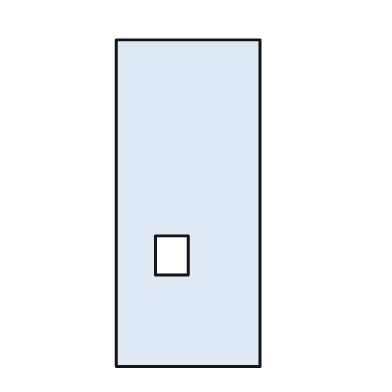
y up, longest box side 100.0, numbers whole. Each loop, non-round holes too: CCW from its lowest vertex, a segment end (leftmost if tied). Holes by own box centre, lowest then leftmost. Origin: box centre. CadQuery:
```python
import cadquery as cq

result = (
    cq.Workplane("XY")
    .moveTo(-22.0, -50.0)
    .lineTo(22.0, -50.0)
    .lineTo(22.0, 50.0)
    .lineTo(-22.0, 50.0)
    .close()
    .moveTo(-10.0, -22.0)
    .lineTo(0.0, -22.0)
    .lineTo(0.0, -10.0)
    .lineTo(-10.0, -10.0)
    .close()
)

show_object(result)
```